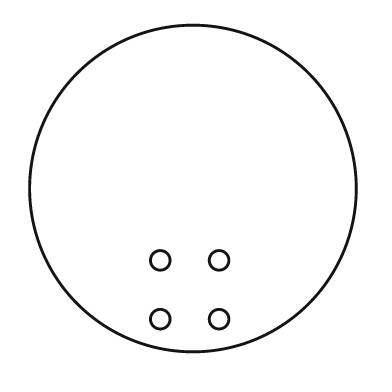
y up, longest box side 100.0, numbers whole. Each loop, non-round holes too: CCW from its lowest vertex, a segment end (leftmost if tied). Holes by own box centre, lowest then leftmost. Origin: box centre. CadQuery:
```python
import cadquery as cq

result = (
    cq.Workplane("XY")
    .moveTo(0.0, 0.0)
    .circle(50.0)
    .moveTo(-10.0, -40.0)
    .circle(3.0)
    .moveTo(8.0, -40.0)
    .circle(3.0)
    .moveTo(-10.0, -22.0)
    .circle(3.0)
    .moveTo(8.0, -22.0)
    .circle(3.0)
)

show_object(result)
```